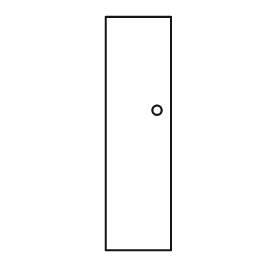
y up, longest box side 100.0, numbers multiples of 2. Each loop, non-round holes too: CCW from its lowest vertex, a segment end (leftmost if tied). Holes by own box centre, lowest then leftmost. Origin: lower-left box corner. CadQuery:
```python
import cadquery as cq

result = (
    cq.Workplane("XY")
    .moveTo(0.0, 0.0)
    .lineTo(28.0, 0.0)
    .lineTo(28.0, 100.0)
    .lineTo(0.0, 100.0)
    .close()
    .moveTo(22.0, 60.0)
    .circle(2.0)
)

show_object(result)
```